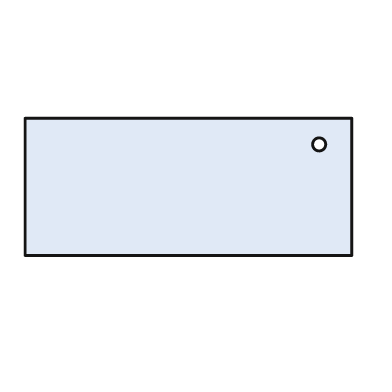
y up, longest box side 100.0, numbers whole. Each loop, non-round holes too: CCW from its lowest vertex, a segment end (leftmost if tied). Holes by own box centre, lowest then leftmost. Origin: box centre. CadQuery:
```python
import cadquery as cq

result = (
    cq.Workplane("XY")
    .moveTo(-50.0, -21.0)
    .lineTo(50.0, -21.0)
    .lineTo(50.0, 21.0)
    .lineTo(-50.0, 21.0)
    .close()
    .moveTo(40.0, 13.0)
    .circle(2.0)
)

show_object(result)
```